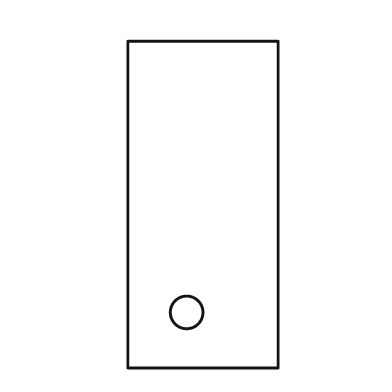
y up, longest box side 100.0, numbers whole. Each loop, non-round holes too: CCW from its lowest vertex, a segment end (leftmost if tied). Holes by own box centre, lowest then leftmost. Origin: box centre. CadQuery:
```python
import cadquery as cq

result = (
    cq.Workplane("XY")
    .moveTo(-23.0, -50.0)
    .lineTo(23.0, -50.0)
    .lineTo(23.0, 50.0)
    .lineTo(-23.0, 50.0)
    .close()
    .moveTo(-5.0, -33.0)
    .circle(5.0)
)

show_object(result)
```